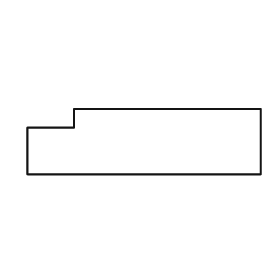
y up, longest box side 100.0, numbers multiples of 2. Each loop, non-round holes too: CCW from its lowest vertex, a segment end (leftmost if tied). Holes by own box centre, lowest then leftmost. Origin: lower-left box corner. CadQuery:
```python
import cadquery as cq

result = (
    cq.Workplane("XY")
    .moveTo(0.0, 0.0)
    .lineTo(100.0, 0.0)
    .lineTo(100.0, 28.0)
    .lineTo(20.0, 28.0)
    .lineTo(20.0, 20.0)
    .lineTo(0.0, 20.0)
    .close()
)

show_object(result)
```